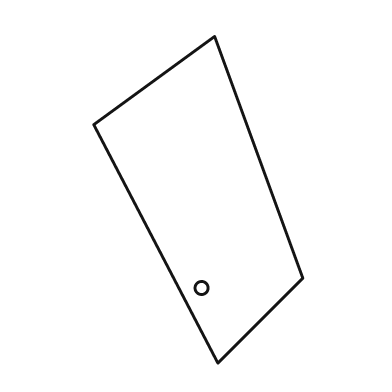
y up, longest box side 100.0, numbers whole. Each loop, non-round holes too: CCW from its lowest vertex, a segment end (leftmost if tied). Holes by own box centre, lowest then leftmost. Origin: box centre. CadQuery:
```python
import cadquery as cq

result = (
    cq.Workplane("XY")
    .moveTo(6.0, -50.0)
    .lineTo(32.0, -24.0)
    .lineTo(5.0, 50.0)
    .lineTo(-32.0, 23.0)
    .close()
    .moveTo(1.0, -27.0)
    .circle(2.0)
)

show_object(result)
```